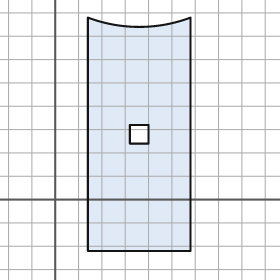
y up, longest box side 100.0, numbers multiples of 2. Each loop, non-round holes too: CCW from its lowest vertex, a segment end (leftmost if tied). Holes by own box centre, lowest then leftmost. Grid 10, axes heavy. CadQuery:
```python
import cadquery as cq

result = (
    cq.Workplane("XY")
    .moveTo(14.0, -22.0)
    .lineTo(58.0, -22.0)
    .lineTo(58.0, 78.0)
    .threePointArc((36.0, 74.0), (14.0, 78.0))
    .close()
    .moveTo(32.0, 24.0)
    .lineTo(40.0, 24.0)
    .lineTo(40.0, 32.0)
    .lineTo(32.0, 32.0)
    .close()
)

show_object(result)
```